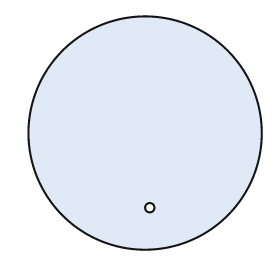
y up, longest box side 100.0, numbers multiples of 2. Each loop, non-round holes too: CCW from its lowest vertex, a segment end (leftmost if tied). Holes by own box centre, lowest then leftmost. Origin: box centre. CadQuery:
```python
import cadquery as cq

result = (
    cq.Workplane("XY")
    .moveTo(0.0, 0.0)
    .circle(50.0)
    .moveTo(2.0, -32.0)
    .circle(2.0)
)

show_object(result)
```